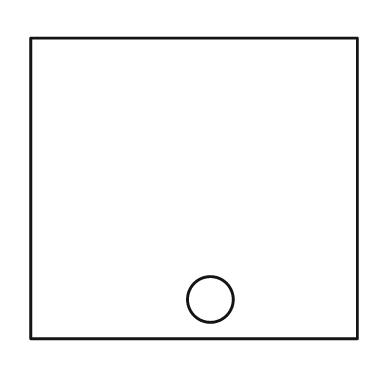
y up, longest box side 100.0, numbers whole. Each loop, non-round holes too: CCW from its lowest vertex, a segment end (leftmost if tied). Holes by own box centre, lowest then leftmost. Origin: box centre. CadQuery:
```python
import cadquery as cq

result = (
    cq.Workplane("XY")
    .moveTo(-50.0, -46.0)
    .lineTo(50.0, -46.0)
    .lineTo(50.0, 46.0)
    .lineTo(-50.0, 46.0)
    .close()
    .moveTo(5.0, -34.0)
    .circle(7.0)
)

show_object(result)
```